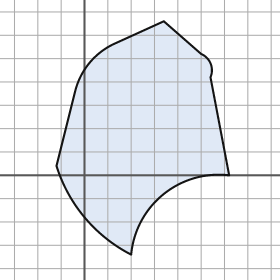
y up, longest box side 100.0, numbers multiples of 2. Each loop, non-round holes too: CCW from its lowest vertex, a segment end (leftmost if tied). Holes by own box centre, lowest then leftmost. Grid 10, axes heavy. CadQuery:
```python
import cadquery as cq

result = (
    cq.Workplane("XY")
    .moveTo(20.0, -34.0)
    .threePointArc((34.0, -8.0), (62.0, 0.0))
    .lineTo(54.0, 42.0)
    .threePointArc((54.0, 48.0), (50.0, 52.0))
    .lineTo(34.0, 66.0)
    .lineTo(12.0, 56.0)
    .threePointArc((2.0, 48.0), (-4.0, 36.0))
    .lineTo(-12.0, 4.0)
    .threePointArc((0.0, -18.0), (20.0, -34.0))
    .close()
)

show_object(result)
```